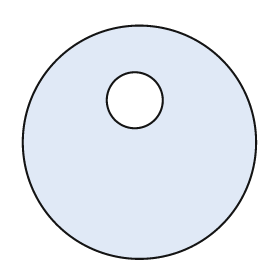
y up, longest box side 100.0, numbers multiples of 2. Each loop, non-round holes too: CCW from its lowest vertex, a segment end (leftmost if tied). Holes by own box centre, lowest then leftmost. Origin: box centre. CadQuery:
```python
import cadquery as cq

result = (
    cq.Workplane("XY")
    .moveTo(0.0, 0.0)
    .circle(50.0)
    .moveTo(-2.0, 18.0)
    .circle(12.0)
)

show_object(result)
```